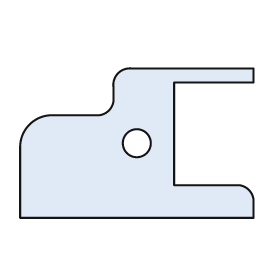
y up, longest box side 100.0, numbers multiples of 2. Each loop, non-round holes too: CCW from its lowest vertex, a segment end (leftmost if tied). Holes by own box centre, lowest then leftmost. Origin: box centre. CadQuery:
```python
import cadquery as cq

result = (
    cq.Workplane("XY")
    .moveTo(-50.0, -32.0)
    .lineTo(50.0, -32.0)
    .lineTo(50.0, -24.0)
    .threePointArc((48.0, -20.0), (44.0, -18.0))
    .lineTo(16.0, -18.0)
    .lineTo(16.0, 26.0)
    .lineTo(50.0, 26.0)
    .lineTo(50.0, 32.0)
    .lineTo(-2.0, 32.0)
    .threePointArc((-8.0, 30.0), (-10.0, 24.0))
    .lineTo(-10.0, 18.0)
    .threePointArc((-12.0, 14.0), (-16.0, 12.0))
    .lineTo(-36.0, 12.0)
    .threePointArc((-46.0, 8.0), (-50.0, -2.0))
    .close()
    .moveTo(0.0, 0.0)
    .circle(6.0)
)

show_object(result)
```